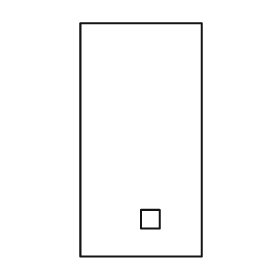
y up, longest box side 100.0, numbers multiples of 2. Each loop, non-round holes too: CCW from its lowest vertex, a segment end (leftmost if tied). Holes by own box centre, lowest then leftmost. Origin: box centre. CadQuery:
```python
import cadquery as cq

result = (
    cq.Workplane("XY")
    .moveTo(-26.0, -50.0)
    .lineTo(26.0, -50.0)
    .lineTo(26.0, 50.0)
    .lineTo(-26.0, 50.0)
    .close()
    .moveTo(0.0, -38.0)
    .lineTo(8.0, -38.0)
    .lineTo(8.0, -30.0)
    .lineTo(0.0, -30.0)
    .close()
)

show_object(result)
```